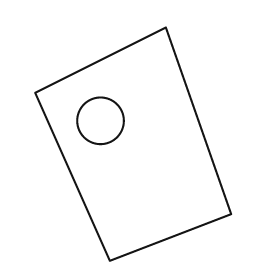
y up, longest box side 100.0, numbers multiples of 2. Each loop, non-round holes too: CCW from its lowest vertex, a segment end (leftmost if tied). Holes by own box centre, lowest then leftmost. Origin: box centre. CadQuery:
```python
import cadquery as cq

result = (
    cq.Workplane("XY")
    .moveTo(-10.0, -50.0)
    .lineTo(42.0, -30.0)
    .lineTo(14.0, 50.0)
    .lineTo(-42.0, 22.0)
    .close()
    .moveTo(-14.0, 10.0)
    .circle(10.0)
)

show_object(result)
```